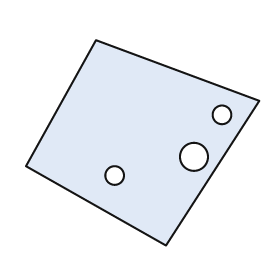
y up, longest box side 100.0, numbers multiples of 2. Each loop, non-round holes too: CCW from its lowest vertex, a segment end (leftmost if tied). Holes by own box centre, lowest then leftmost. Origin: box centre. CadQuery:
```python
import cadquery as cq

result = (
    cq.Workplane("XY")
    .moveTo(10.0, -44.0)
    .lineTo(50.0, 18.0)
    .lineTo(-20.0, 44.0)
    .lineTo(-50.0, -10.0)
    .close()
    .moveTo(-12.0, -14.0)
    .circle(4.0)
    .moveTo(22.0, -6.0)
    .circle(6.0)
    .moveTo(34.0, 12.0)
    .circle(4.0)
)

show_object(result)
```